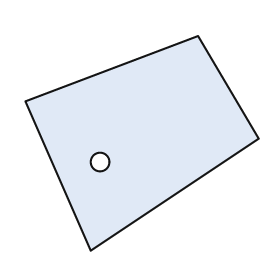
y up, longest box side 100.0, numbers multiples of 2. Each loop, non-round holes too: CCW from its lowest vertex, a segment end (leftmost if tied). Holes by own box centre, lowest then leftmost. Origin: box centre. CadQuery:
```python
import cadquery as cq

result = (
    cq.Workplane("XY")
    .moveTo(-22.0, -46.0)
    .lineTo(50.0, 2.0)
    .lineTo(24.0, 46.0)
    .lineTo(-50.0, 18.0)
    .close()
    .moveTo(-18.0, -8.0)
    .circle(4.0)
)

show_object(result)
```